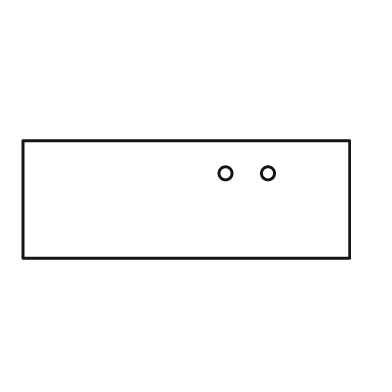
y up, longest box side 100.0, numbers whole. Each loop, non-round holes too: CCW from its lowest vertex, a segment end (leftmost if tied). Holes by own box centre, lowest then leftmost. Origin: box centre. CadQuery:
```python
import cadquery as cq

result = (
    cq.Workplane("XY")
    .moveTo(-50.0, -18.0)
    .lineTo(50.0, -18.0)
    .lineTo(50.0, 18.0)
    .lineTo(-50.0, 18.0)
    .close()
    .moveTo(12.0, 8.0)
    .circle(2.0)
    .moveTo(25.0, 8.0)
    .circle(2.0)
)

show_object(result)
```